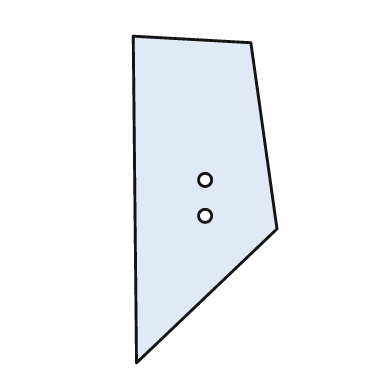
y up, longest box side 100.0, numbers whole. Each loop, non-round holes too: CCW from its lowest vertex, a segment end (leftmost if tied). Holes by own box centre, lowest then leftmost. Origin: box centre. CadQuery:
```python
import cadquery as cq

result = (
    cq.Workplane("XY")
    .moveTo(-21.0, -50.0)
    .lineTo(22.0, -9.0)
    .lineTo(14.0, 48.0)
    .lineTo(-22.0, 50.0)
    .close()
    .moveTo(0.0, -5.0)
    .circle(2.0)
    .moveTo(0.0, 6.0)
    .circle(2.0)
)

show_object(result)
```